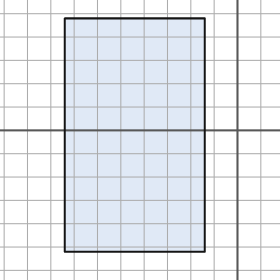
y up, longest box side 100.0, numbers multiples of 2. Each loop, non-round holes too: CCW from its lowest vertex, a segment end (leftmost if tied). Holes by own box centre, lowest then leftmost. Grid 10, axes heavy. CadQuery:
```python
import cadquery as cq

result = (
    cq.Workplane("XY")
    .moveTo(-74.0, -52.0)
    .lineTo(-14.0, -52.0)
    .lineTo(-14.0, 48.0)
    .lineTo(-74.0, 48.0)
    .close()
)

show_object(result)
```